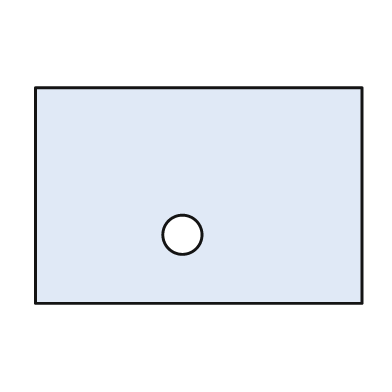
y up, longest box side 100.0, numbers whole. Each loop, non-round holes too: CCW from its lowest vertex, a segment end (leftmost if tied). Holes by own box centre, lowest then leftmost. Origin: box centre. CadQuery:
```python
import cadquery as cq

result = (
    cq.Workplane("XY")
    .moveTo(-50.0, -33.0)
    .lineTo(50.0, -33.0)
    .lineTo(50.0, 33.0)
    .lineTo(-50.0, 33.0)
    .close()
    .moveTo(-5.0, -12.0)
    .circle(6.0)
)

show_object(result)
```